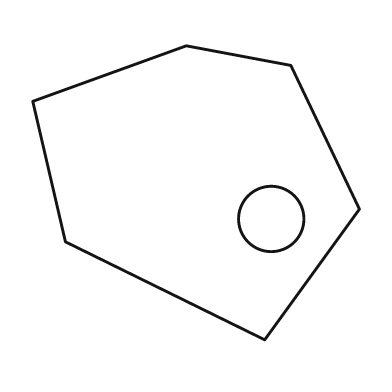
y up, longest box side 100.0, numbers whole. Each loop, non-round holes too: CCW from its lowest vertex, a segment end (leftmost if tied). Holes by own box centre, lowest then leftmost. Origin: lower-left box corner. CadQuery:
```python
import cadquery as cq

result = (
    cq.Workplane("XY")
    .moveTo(71.0, 0.0)
    .lineTo(100.0, 40.0)
    .lineTo(79.0, 84.0)
    .lineTo(47.0, 90.0)
    .lineTo(0.0, 73.0)
    .lineTo(10.0, 30.0)
    .close()
    .moveTo(73.0, 37.0)
    .circle(10.0)
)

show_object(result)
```